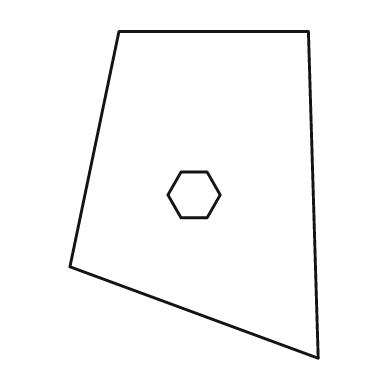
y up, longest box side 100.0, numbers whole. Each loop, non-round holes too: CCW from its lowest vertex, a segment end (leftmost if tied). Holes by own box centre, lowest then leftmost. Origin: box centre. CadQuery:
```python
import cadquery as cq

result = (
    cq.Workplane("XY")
    .moveTo(38.0, -50.0)
    .lineTo(35.0, 50.0)
    .lineTo(-23.0, 50.0)
    .lineTo(-38.0, -22.0)
    .close()
    .moveTo(-4.0, -7.0)
    .lineTo(4.0, -7.0)
    .lineTo(8.0, 0.0)
    .lineTo(4.0, 7.0)
    .lineTo(-4.0, 7.0)
    .lineTo(-8.0, 0.0)
    .close()
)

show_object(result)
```